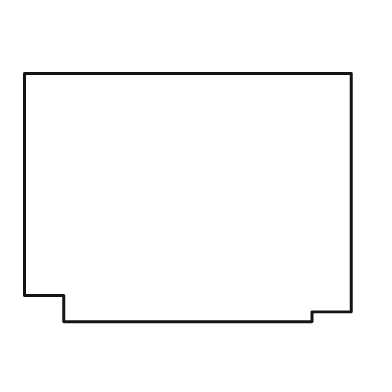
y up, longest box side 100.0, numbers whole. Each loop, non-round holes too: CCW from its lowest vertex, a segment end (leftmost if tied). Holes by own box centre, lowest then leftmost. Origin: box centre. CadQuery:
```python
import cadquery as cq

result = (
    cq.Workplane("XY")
    .moveTo(-38.0, -38.0)
    .lineTo(38.0, -38.0)
    .lineTo(38.0, -35.0)
    .lineTo(50.0, -35.0)
    .lineTo(50.0, 38.0)
    .lineTo(-50.0, 38.0)
    .lineTo(-50.0, -30.0)
    .lineTo(-38.0, -30.0)
    .close()
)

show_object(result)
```